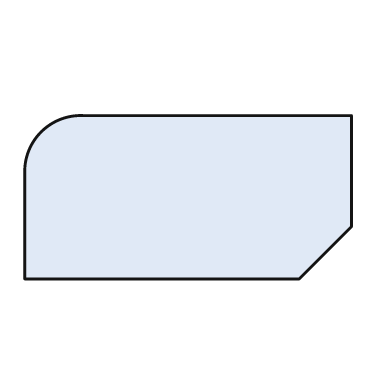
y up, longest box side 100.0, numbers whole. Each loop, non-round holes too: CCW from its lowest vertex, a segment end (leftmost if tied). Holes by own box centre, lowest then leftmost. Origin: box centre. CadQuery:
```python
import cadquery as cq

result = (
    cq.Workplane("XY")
    .moveTo(-50.0, -25.0)
    .lineTo(34.0, -25.0)
    .lineTo(50.0, -9.0)
    .lineTo(50.0, 25.0)
    .lineTo(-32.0, 25.0)
    .threePointArc((-45.0, 20.0), (-50.0, 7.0))
    .close()
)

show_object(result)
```